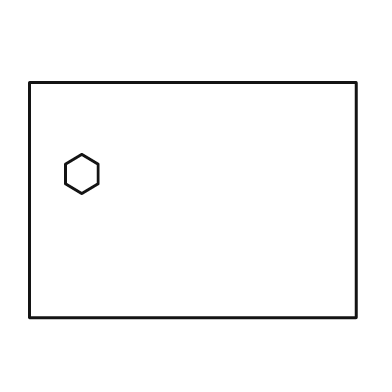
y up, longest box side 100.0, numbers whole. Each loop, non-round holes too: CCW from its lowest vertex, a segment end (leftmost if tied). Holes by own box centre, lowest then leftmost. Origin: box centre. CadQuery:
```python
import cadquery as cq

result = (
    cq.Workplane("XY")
    .moveTo(-50.0, -36.0)
    .lineTo(50.0, -36.0)
    .lineTo(50.0, 36.0)
    .lineTo(-50.0, 36.0)
    .close()
    .moveTo(-34.0, 2.0)
    .lineTo(-29.0, 5.0)
    .lineTo(-29.0, 11.0)
    .lineTo(-34.0, 14.0)
    .lineTo(-39.0, 11.0)
    .lineTo(-39.0, 5.0)
    .close()
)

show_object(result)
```